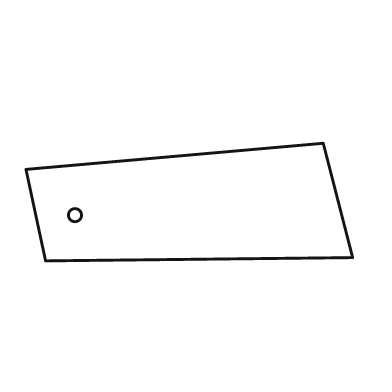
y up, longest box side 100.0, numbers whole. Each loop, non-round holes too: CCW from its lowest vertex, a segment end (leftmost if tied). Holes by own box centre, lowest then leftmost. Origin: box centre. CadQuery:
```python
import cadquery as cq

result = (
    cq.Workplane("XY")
    .moveTo(-44.0, -18.0)
    .lineTo(50.0, -17.0)
    .lineTo(41.0, 18.0)
    .lineTo(-50.0, 10.0)
    .close()
    .moveTo(-35.0, -4.0)
    .circle(2.0)
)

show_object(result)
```